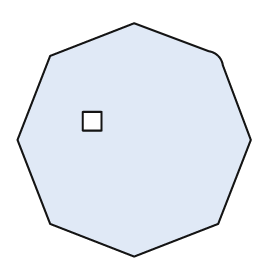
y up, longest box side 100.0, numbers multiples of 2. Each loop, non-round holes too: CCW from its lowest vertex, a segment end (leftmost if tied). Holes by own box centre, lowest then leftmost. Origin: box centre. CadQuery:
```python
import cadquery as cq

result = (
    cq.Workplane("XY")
    .moveTo(0.0, -50.0)
    .lineTo(36.0, -36.0)
    .lineTo(50.0, 0.0)
    .lineTo(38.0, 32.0)
    .threePointArc((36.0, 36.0), (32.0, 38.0))
    .lineTo(0.0, 50.0)
    .lineTo(-36.0, 36.0)
    .lineTo(-50.0, 0.0)
    .lineTo(-36.0, -36.0)
    .close()
    .moveTo(-22.0, 4.0)
    .lineTo(-14.0, 4.0)
    .lineTo(-14.0, 12.0)
    .lineTo(-22.0, 12.0)
    .close()
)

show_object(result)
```